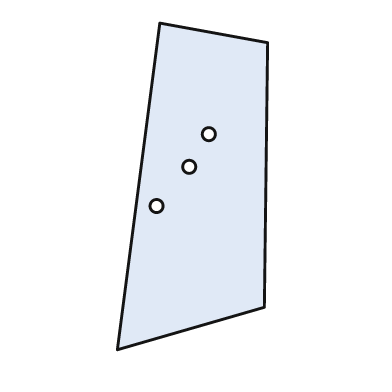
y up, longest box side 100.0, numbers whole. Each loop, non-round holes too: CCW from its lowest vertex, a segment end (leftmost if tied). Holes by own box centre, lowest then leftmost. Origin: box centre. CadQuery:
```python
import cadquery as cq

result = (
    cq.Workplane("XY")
    .moveTo(-23.0, -50.0)
    .lineTo(22.0, -37.0)
    .lineTo(23.0, 44.0)
    .lineTo(-10.0, 50.0)
    .close()
    .moveTo(-11.0, -6.0)
    .circle(2.0)
    .moveTo(-1.0, 6.0)
    .circle(2.0)
    .moveTo(5.0, 16.0)
    .circle(2.0)
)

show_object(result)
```